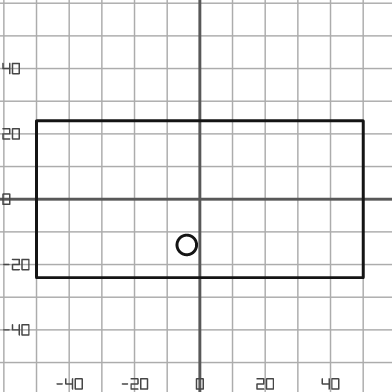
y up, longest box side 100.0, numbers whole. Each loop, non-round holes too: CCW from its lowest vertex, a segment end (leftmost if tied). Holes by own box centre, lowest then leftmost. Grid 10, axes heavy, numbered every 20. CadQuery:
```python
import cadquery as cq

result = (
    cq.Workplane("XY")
    .moveTo(-50.0, -24.0)
    .lineTo(50.0, -24.0)
    .lineTo(50.0, 24.0)
    .lineTo(-50.0, 24.0)
    .close()
    .moveTo(-4.0, -14.0)
    .circle(3.0)
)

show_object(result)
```